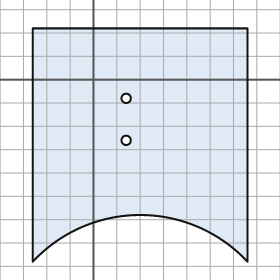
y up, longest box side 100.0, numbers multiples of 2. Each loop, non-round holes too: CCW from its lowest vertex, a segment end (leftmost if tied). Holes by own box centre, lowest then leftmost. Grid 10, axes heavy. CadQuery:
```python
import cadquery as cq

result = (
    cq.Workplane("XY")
    .moveTo(-26.0, -78.0)
    .threePointArc((20.0, -58.0), (66.0, -78.0))
    .lineTo(66.0, 22.0)
    .lineTo(-26.0, 22.0)
    .close()
    .moveTo(14.0, -26.0)
    .circle(2.0)
    .moveTo(14.0, -8.0)
    .circle(2.0)
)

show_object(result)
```